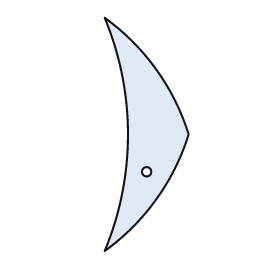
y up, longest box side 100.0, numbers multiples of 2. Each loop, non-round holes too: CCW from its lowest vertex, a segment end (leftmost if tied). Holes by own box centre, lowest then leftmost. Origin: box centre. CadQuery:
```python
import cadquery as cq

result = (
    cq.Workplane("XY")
    .moveTo(-18.0, -50.0)
    .threePointArc((4.0, -28.0), (18.0, 0.0))
    .threePointArc((4.0, 28.0), (-18.0, 50.0))
    .threePointArc((-8.0, 0.0), (-18.0, -50.0))
    .close()
    .moveTo(0.0, -16.0)
    .circle(2.0)
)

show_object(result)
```